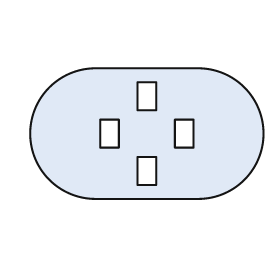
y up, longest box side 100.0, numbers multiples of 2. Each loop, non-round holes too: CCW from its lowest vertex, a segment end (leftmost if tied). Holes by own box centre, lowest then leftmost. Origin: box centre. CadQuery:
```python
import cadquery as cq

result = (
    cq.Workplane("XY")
    .moveTo(-22.0, -28.0)
    .lineTo(22.0, -28.0)
    .threePointArc((50.0, 0.0), (22.0, 28.0))
    .lineTo(-22.0, 28.0)
    .threePointArc((-50.0, 0.0), (-22.0, -28.0))
    .close()
    .moveTo(-4.0, -22.0)
    .lineTo(4.0, -22.0)
    .lineTo(4.0, -10.0)
    .lineTo(-4.0, -10.0)
    .close()
    .moveTo(-20.0, -6.0)
    .lineTo(-12.0, -6.0)
    .lineTo(-12.0, 6.0)
    .lineTo(-20.0, 6.0)
    .close()
    .moveTo(12.0, -6.0)
    .lineTo(20.0, -6.0)
    .lineTo(20.0, 6.0)
    .lineTo(12.0, 6.0)
    .close()
    .moveTo(-4.0, 10.0)
    .lineTo(4.0, 10.0)
    .lineTo(4.0, 22.0)
    .lineTo(-4.0, 22.0)
    .close()
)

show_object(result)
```